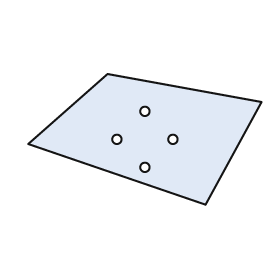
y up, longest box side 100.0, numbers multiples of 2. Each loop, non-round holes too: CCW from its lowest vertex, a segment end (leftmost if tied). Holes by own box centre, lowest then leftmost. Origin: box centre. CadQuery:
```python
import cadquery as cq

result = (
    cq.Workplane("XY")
    .moveTo(26.0, -28.0)
    .lineTo(50.0, 16.0)
    .lineTo(-16.0, 28.0)
    .lineTo(-50.0, -2.0)
    .close()
    .moveTo(0.0, -12.0)
    .circle(2.0)
    .moveTo(-12.0, 0.0)
    .circle(2.0)
    .moveTo(12.0, 0.0)
    .circle(2.0)
    .moveTo(0.0, 12.0)
    .circle(2.0)
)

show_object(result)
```